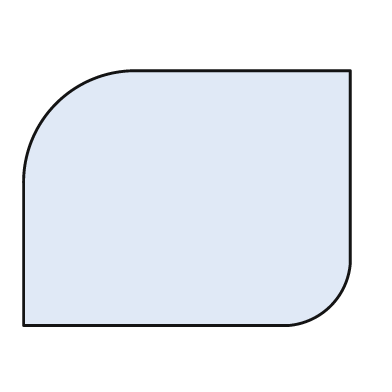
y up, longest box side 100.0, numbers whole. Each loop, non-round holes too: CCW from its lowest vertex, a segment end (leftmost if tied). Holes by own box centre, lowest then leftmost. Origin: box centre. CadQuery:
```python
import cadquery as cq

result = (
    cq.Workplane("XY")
    .moveTo(-50.0, -39.0)
    .lineTo(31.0, -39.0)
    .threePointArc((44.0, -33.0), (50.0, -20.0))
    .lineTo(50.0, 39.0)
    .lineTo(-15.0, 39.0)
    .threePointArc((-40.0, 29.0), (-50.0, 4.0))
    .close()
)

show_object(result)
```